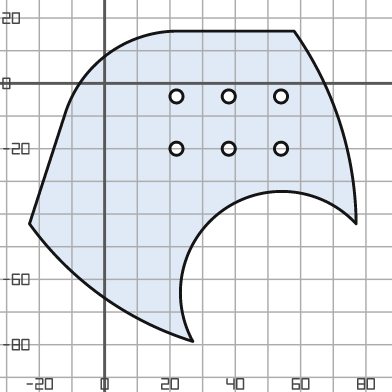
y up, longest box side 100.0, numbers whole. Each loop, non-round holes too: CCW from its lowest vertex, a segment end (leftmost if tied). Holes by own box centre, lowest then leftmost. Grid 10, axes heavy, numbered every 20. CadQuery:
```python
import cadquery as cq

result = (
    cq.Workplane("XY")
    .moveTo(27.0, -79.0)
    .threePointArc((36.0, -39.0), (77.0, -43.0))
    .threePointArc((72.0, -12.0), (58.0, 16.0))
    .lineTo(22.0, 16.0)
    .threePointArc((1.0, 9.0), (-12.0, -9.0))
    .lineTo(-23.0, -43.0)
    .threePointArc((-1.0, -65.0), (27.0, -79.0))
    .close()
    .moveTo(22.0, -20.0)
    .circle(2.0)
    .moveTo(38.0, -20.0)
    .circle(2.0)
    .moveTo(54.0, -20.0)
    .circle(2.0)
    .moveTo(22.0, -4.0)
    .circle(2.0)
    .moveTo(38.0, -4.0)
    .circle(2.0)
    .moveTo(54.0, -4.0)
    .circle(2.0)
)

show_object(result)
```